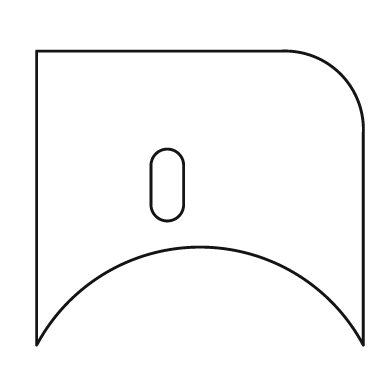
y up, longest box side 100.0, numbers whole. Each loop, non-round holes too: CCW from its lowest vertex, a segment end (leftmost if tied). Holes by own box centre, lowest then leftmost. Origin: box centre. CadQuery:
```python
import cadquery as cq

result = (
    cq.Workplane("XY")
    .moveTo(-50.0, -45.0)
    .threePointArc((0.0, -15.0), (50.0, -45.0))
    .lineTo(50.0, 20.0)
    .threePointArc((43.0, 38.0), (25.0, 45.0))
    .lineTo(-50.0, 45.0)
    .close()
    .moveTo(-15.0, -2.0)
    .threePointArc((-10.0, -7.0), (-5.0, -2.0))
    .lineTo(-5.0, 10.0)
    .threePointArc((-10.0, 15.0), (-15.0, 10.0))
    .close()
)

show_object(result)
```